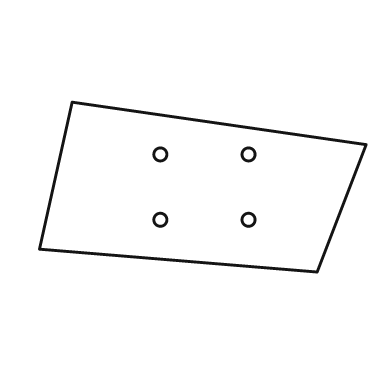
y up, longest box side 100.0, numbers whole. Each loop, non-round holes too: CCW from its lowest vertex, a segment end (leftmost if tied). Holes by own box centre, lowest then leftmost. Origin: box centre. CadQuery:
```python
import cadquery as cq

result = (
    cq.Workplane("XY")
    .moveTo(35.0, -26.0)
    .lineTo(50.0, 13.0)
    .lineTo(-40.0, 26.0)
    .lineTo(-50.0, -19.0)
    .close()
    .moveTo(-13.0, -10.0)
    .circle(2.0)
    .moveTo(14.0, -10.0)
    .circle(2.0)
    .moveTo(-13.0, 10.0)
    .circle(2.0)
    .moveTo(14.0, 10.0)
    .circle(2.0)
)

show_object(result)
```